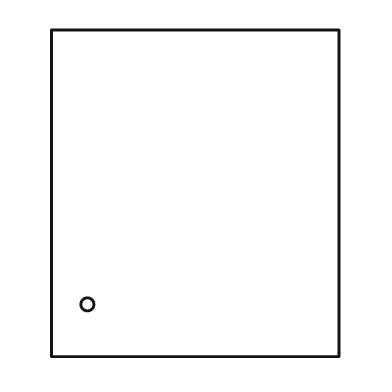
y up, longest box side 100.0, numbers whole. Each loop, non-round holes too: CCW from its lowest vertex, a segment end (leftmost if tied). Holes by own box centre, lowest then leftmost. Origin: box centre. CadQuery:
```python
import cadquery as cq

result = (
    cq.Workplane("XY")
    .moveTo(-44.0, -50.0)
    .lineTo(44.0, -50.0)
    .lineTo(44.0, 50.0)
    .lineTo(-44.0, 50.0)
    .close()
    .moveTo(-33.0, -34.0)
    .circle(2.0)
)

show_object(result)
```